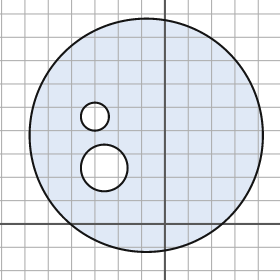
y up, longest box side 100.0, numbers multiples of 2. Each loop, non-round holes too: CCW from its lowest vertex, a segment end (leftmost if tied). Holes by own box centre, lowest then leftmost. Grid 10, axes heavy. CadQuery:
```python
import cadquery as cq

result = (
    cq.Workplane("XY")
    .moveTo(-8.0, 38.0)
    .circle(50.0)
    .moveTo(-26.0, 24.0)
    .circle(10.0)
    .moveTo(-30.0, 46.0)
    .circle(6.0)
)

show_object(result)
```